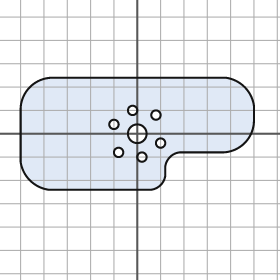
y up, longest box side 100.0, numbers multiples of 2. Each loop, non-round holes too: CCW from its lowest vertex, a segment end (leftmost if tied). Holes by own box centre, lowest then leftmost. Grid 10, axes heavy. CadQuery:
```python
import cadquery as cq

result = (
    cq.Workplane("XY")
    .moveTo(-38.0, -24.0)
    .lineTo(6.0, -24.0)
    .threePointArc((10.0, -22.0), (12.0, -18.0))
    .lineTo(12.0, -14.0)
    .threePointArc((14.0, -10.0), (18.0, -8.0))
    .lineTo(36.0, -8.0)
    .threePointArc((46.0, -4.0), (50.0, 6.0))
    .lineTo(50.0, 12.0)
    .threePointArc((46.0, 20.0), (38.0, 24.0))
    .lineTo(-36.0, 24.0)
    .threePointArc((-46.0, 20.0), (-50.0, 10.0))
    .lineTo(-50.0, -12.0)
    .threePointArc((-46.0, -20.0), (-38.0, -24.0))
    .close()
    .moveTo(2.0, -10.0)
    .circle(2.0)
    .moveTo(-8.0, -8.0)
    .circle(2.0)
    .moveTo(10.0, -4.0)
    .circle(2.0)
    .moveTo(0.0, 0.0)
    .circle(4.0)
    .moveTo(-10.0, 4.0)
    .circle(2.0)
    .moveTo(8.0, 8.0)
    .circle(2.0)
    .moveTo(-2.0, 10.0)
    .circle(2.0)
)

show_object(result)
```